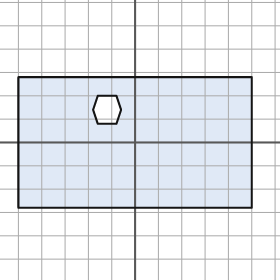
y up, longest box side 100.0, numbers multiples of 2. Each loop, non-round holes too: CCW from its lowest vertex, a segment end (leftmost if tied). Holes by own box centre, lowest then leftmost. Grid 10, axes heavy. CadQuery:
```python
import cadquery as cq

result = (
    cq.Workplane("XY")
    .moveTo(-50.0, -28.0)
    .lineTo(50.0, -28.0)
    .lineTo(50.0, 28.0)
    .lineTo(-50.0, 28.0)
    .close()
    .moveTo(-16.0, 8.0)
    .lineTo(-8.0, 8.0)
    .lineTo(-6.0, 14.0)
    .lineTo(-8.0, 20.0)
    .lineTo(-16.0, 20.0)
    .lineTo(-18.0, 14.0)
    .close()
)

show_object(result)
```